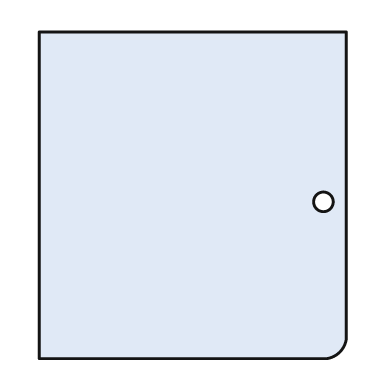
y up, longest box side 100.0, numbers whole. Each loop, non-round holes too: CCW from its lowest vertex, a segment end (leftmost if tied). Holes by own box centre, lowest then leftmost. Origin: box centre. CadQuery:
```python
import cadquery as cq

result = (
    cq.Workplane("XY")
    .moveTo(-47.0, -50.0)
    .lineTo(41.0, -50.0)
    .threePointArc((45.0, -48.0), (47.0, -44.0))
    .lineTo(47.0, 50.0)
    .lineTo(-47.0, 50.0)
    .close()
    .moveTo(40.0, -2.0)
    .circle(3.0)
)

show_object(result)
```